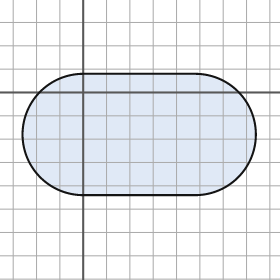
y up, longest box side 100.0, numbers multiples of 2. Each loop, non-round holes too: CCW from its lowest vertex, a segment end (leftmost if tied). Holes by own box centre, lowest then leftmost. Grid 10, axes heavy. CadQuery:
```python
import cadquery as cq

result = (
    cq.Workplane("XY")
    .moveTo(0.0, -44.0)
    .lineTo(48.0, -44.0)
    .threePointArc((74.0, -18.0), (48.0, 8.0))
    .lineTo(0.0, 8.0)
    .threePointArc((-26.0, -18.0), (0.0, -44.0))
    .close()
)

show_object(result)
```